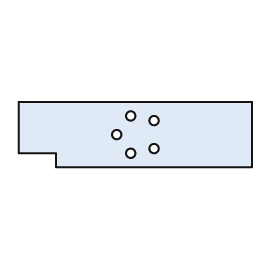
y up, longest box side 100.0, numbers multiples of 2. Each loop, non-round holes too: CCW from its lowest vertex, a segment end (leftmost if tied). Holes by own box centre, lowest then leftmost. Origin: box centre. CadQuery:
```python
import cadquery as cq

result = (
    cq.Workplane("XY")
    .moveTo(-34.0, -14.0)
    .lineTo(50.0, -14.0)
    .lineTo(50.0, 14.0)
    .lineTo(-50.0, 14.0)
    .lineTo(-50.0, -8.0)
    .lineTo(-34.0, -8.0)
    .close()
    .moveTo(-2.0, -8.0)
    .circle(2.0)
    .moveTo(8.0, -6.0)
    .circle(2.0)
    .moveTo(-8.0, 0.0)
    .circle(2.0)
    .moveTo(8.0, 6.0)
    .circle(2.0)
    .moveTo(-2.0, 8.0)
    .circle(2.0)
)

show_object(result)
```